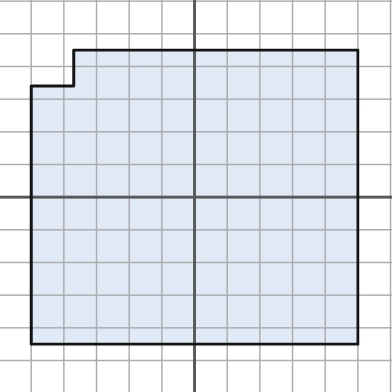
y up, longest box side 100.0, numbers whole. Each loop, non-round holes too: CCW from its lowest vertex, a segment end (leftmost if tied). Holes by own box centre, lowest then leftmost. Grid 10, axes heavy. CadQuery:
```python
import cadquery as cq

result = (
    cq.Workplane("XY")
    .moveTo(-50.0, -45.0)
    .lineTo(50.0, -45.0)
    .lineTo(50.0, 45.0)
    .lineTo(-37.0, 45.0)
    .lineTo(-37.0, 34.0)
    .lineTo(-50.0, 34.0)
    .close()
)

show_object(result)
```